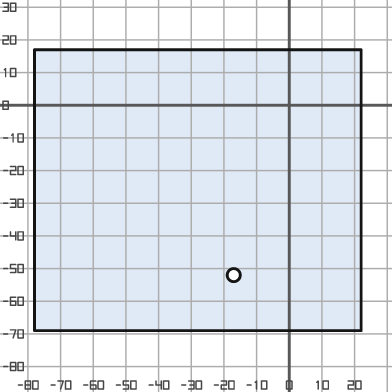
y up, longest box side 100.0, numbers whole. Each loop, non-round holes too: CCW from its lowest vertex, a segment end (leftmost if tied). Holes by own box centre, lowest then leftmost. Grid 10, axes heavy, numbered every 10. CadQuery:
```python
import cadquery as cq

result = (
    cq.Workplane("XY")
    .moveTo(-78.0, -69.0)
    .lineTo(22.0, -69.0)
    .lineTo(22.0, 17.0)
    .lineTo(-78.0, 17.0)
    .close()
    .moveTo(-17.0, -52.0)
    .circle(2.0)
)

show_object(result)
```